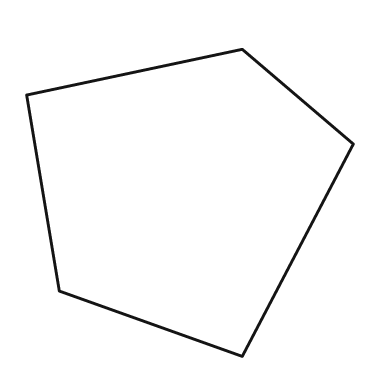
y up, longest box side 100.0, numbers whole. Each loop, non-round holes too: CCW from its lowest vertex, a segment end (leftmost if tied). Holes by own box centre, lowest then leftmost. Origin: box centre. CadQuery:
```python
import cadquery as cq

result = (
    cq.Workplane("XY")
    .moveTo(16.0, -47.0)
    .lineTo(50.0, 18.0)
    .lineTo(16.0, 47.0)
    .lineTo(-50.0, 33.0)
    .lineTo(-40.0, -27.0)
    .close()
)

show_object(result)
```